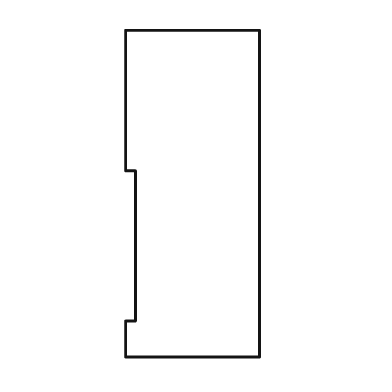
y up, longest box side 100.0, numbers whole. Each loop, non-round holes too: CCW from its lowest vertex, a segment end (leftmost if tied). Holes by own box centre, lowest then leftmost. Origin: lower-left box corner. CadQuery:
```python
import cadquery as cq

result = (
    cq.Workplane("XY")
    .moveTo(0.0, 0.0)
    .lineTo(41.0, 0.0)
    .lineTo(41.0, 100.0)
    .lineTo(0.0, 100.0)
    .lineTo(0.0, 57.0)
    .lineTo(3.0, 57.0)
    .lineTo(3.0, 11.0)
    .lineTo(0.0, 11.0)
    .close()
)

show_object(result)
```